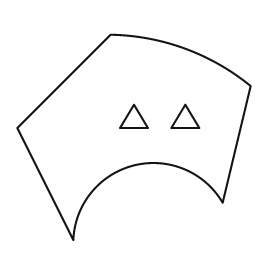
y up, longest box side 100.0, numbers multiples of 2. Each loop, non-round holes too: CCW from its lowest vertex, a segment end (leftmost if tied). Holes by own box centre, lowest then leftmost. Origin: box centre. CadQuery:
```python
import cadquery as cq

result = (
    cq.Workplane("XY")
    .moveTo(-26.0, -44.0)
    .threePointArc((0.0, -12.0), (38.0, -28.0))
    .lineTo(50.0, 22.0)
    .threePointArc((22.0, 38.0), (-10.0, 44.0))
    .lineTo(-50.0, 4.0)
    .close()
    .moveTo(-6.0, 4.0)
    .lineTo(6.0, 4.0)
    .lineTo(0.0, 14.0)
    .close()
    .moveTo(16.0, 4.0)
    .lineTo(28.0, 4.0)
    .lineTo(22.0, 14.0)
    .close()
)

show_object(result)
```